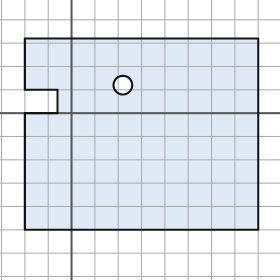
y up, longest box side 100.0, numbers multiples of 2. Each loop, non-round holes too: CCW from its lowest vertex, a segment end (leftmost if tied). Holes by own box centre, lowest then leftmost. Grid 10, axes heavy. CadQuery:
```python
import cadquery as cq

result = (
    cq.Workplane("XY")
    .moveTo(-20.0, -50.0)
    .lineTo(80.0, -50.0)
    .lineTo(80.0, 32.0)
    .lineTo(-20.0, 32.0)
    .lineTo(-20.0, 10.0)
    .lineTo(-6.0, 10.0)
    .lineTo(-6.0, 0.0)
    .lineTo(-20.0, 0.0)
    .close()
    .moveTo(22.0, 12.0)
    .circle(4.0)
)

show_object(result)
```